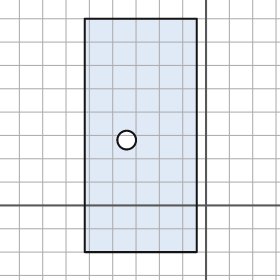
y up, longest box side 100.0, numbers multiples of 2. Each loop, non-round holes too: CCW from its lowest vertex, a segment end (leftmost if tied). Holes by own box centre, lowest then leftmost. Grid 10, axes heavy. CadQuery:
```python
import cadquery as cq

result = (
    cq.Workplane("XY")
    .moveTo(-52.0, -20.0)
    .lineTo(-4.0, -20.0)
    .lineTo(-4.0, 80.0)
    .lineTo(-52.0, 80.0)
    .close()
    .moveTo(-34.0, 28.0)
    .circle(4.0)
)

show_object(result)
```